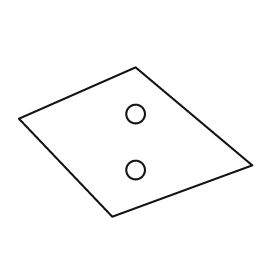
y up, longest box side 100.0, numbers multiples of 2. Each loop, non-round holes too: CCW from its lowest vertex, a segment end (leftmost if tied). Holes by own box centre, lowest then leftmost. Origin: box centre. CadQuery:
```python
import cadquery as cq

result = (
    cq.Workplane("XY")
    .moveTo(-10.0, -32.0)
    .lineTo(50.0, -10.0)
    .lineTo(0.0, 32.0)
    .lineTo(-50.0, 10.0)
    .close()
    .moveTo(0.0, -12.0)
    .circle(4.0)
    .moveTo(0.0, 12.0)
    .circle(4.0)
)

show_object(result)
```